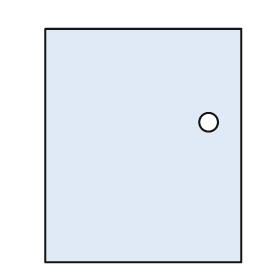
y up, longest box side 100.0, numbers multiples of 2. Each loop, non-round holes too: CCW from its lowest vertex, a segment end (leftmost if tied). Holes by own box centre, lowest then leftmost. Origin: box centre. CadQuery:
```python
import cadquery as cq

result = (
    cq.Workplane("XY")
    .moveTo(-42.0, -50.0)
    .lineTo(42.0, -50.0)
    .lineTo(42.0, 50.0)
    .lineTo(-42.0, 50.0)
    .close()
    .moveTo(28.0, 10.0)
    .circle(4.0)
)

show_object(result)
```